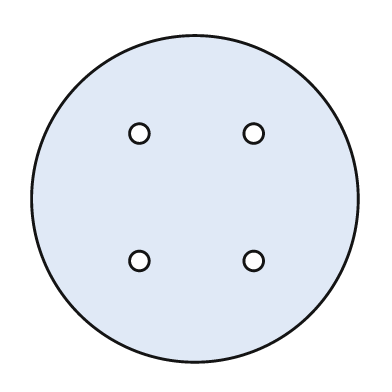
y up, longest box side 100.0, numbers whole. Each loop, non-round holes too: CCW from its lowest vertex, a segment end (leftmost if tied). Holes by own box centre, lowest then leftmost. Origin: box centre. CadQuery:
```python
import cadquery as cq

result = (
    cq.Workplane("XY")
    .moveTo(0.0, 0.0)
    .circle(50.0)
    .moveTo(-17.0, -19.0)
    .circle(3.0)
    .moveTo(18.0, -19.0)
    .circle(3.0)
    .moveTo(-17.0, 20.0)
    .circle(3.0)
    .moveTo(18.0, 20.0)
    .circle(3.0)
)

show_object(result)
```